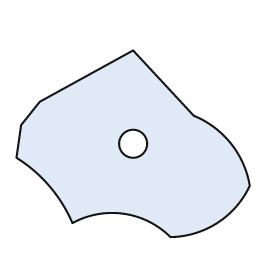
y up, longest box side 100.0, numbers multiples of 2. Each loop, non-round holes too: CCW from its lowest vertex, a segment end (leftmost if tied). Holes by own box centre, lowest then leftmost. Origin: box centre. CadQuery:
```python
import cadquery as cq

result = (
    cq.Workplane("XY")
    .moveTo(16.0, -40.0)
    .threePointArc((36.0, -34.0), (50.0, -18.0))
    .threePointArc((42.0, 0.0), (26.0, 12.0))
    .lineTo(0.0, 40.0)
    .lineTo(-40.0, 18.0)
    .lineTo(-48.0, 8.0)
    .lineTo(-50.0, -6.0)
    .threePointArc((-36.0, -18.0), (-26.0, -34.0))
    .threePointArc((-4.0, -30.0), (16.0, -40.0))
    .close()
    .moveTo(0.0, 0.0)
    .circle(6.0)
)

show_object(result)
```